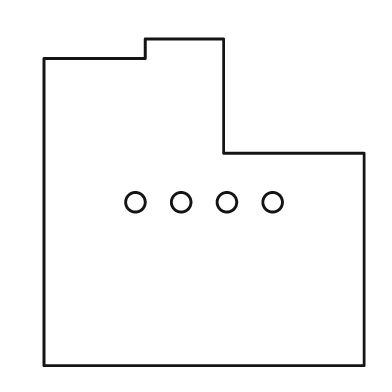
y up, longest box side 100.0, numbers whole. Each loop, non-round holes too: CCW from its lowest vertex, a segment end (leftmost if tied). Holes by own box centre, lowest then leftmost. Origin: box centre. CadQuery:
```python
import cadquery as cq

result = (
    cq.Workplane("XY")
    .moveTo(-49.0, -50.0)
    .lineTo(49.0, -50.0)
    .lineTo(49.0, 15.0)
    .lineTo(6.0, 15.0)
    .lineTo(6.0, 50.0)
    .lineTo(-18.0, 50.0)
    .lineTo(-18.0, 44.0)
    .lineTo(-49.0, 44.0)
    .close()
    .moveTo(-21.0, 0.0)
    .circle(3.0)
    .moveTo(-7.0, 0.0)
    .circle(3.0)
    .moveTo(7.0, 0.0)
    .circle(3.0)
    .moveTo(21.0, 0.0)
    .circle(3.0)
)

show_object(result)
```